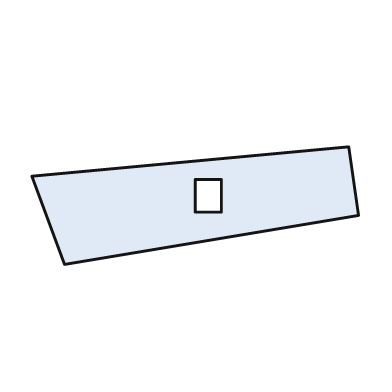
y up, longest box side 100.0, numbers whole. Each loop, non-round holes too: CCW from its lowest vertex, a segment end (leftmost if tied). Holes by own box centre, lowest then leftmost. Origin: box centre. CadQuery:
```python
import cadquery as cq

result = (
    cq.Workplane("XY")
    .moveTo(-40.0, -18.0)
    .lineTo(50.0, -3.0)
    .lineTo(47.0, 18.0)
    .lineTo(-50.0, 9.0)
    .close()
    .moveTo(0.0, -2.0)
    .lineTo(8.0, -2.0)
    .lineTo(8.0, 8.0)
    .lineTo(0.0, 8.0)
    .close()
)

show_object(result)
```